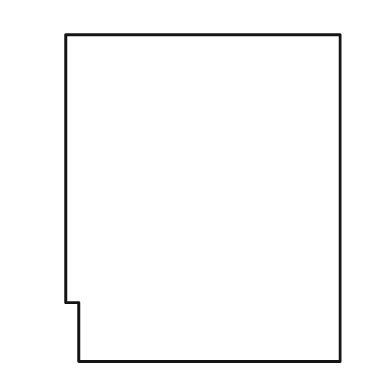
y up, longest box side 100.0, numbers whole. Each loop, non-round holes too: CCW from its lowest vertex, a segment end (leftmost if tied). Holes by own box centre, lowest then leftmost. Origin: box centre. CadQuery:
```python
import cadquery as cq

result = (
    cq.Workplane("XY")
    .moveTo(-38.0, -50.0)
    .lineTo(42.0, -50.0)
    .lineTo(42.0, 50.0)
    .lineTo(-42.0, 50.0)
    .lineTo(-42.0, -32.0)
    .lineTo(-38.0, -32.0)
    .close()
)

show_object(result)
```